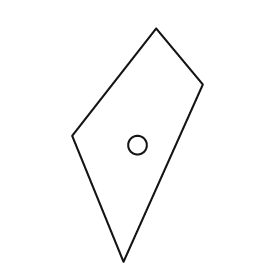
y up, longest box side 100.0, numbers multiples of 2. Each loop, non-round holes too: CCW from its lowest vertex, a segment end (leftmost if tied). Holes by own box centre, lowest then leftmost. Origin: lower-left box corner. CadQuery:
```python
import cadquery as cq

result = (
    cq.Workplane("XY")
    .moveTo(22.0, 0.0)
    .lineTo(56.0, 76.0)
    .lineTo(36.0, 100.0)
    .lineTo(0.0, 54.0)
    .close()
    .moveTo(28.0, 50.0)
    .circle(4.0)
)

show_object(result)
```